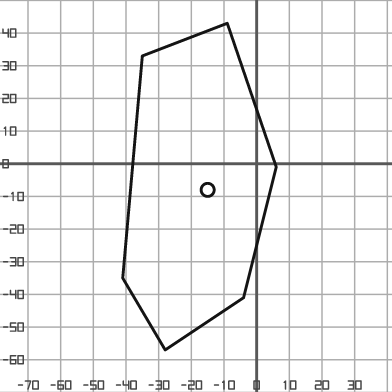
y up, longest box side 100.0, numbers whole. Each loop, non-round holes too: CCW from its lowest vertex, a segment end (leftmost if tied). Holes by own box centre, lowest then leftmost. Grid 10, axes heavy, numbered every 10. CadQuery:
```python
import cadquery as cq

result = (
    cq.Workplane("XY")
    .moveTo(-28.0, -57.0)
    .lineTo(-4.0, -41.0)
    .lineTo(6.0, -1.0)
    .lineTo(-9.0, 43.0)
    .lineTo(-35.0, 33.0)
    .lineTo(-41.0, -35.0)
    .close()
    .moveTo(-15.0, -8.0)
    .circle(2.0)
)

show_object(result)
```